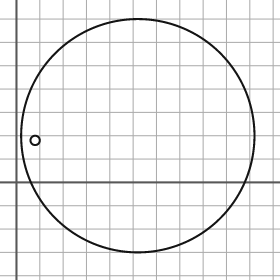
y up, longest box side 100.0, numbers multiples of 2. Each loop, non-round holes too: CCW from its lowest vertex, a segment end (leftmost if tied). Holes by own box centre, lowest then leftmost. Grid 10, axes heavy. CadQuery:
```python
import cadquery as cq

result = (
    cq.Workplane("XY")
    .moveTo(52.0, 20.0)
    .circle(50.0)
    .moveTo(8.0, 18.0)
    .circle(2.0)
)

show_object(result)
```